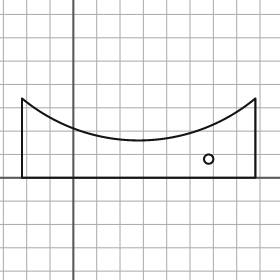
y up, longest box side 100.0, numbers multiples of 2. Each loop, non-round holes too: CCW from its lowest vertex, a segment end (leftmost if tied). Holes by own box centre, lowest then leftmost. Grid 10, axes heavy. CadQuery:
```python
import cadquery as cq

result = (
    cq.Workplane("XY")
    .moveTo(-22.0, 0.0)
    .lineTo(78.0, 0.0)
    .lineTo(78.0, 34.0)
    .threePointArc((28.0, 16.0), (-22.0, 34.0))
    .close()
    .moveTo(58.0, 8.0)
    .circle(2.0)
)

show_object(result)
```